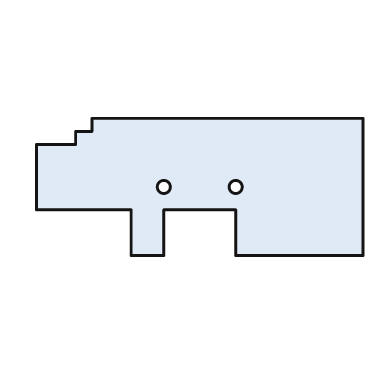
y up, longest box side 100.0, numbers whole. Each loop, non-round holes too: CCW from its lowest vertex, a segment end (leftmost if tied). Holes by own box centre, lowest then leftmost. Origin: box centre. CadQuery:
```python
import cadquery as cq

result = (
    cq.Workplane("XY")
    .moveTo(-21.0, -21.0)
    .lineTo(-11.0, -21.0)
    .lineTo(-11.0, -7.0)
    .lineTo(11.0, -7.0)
    .lineTo(11.0, -21.0)
    .lineTo(50.0, -21.0)
    .lineTo(50.0, 21.0)
    .lineTo(-33.0, 21.0)
    .lineTo(-33.0, 17.0)
    .lineTo(-38.0, 17.0)
    .lineTo(-38.0, 13.0)
    .lineTo(-50.0, 13.0)
    .lineTo(-50.0, -7.0)
    .lineTo(-21.0, -7.0)
    .close()
    .moveTo(-11.0, 0.0)
    .circle(2.0)
    .moveTo(11.0, 0.0)
    .circle(2.0)
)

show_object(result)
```